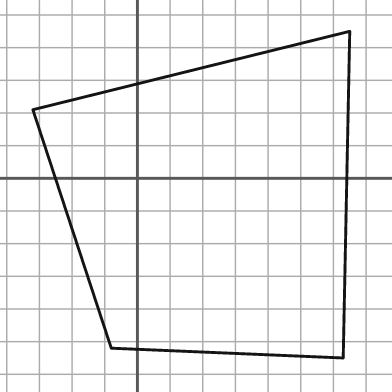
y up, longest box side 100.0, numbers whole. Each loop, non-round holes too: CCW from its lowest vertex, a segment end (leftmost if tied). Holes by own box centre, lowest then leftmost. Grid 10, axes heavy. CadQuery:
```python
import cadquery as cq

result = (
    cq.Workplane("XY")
    .moveTo(63.0, -55.0)
    .lineTo(65.0, 45.0)
    .lineTo(-32.0, 21.0)
    .lineTo(-8.0, -52.0)
    .close()
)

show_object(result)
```